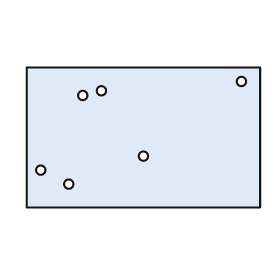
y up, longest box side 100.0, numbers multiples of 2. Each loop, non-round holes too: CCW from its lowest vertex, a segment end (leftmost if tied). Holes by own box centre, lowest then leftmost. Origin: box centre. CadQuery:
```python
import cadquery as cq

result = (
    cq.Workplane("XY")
    .moveTo(-50.0, -30.0)
    .lineTo(50.0, -30.0)
    .lineTo(50.0, 30.0)
    .lineTo(-50.0, 30.0)
    .close()
    .moveTo(-32.0, -20.0)
    .circle(2.0)
    .moveTo(-44.0, -14.0)
    .circle(2.0)
    .moveTo(0.0, -8.0)
    .circle(2.0)
    .moveTo(-26.0, 18.0)
    .circle(2.0)
    .moveTo(-18.0, 20.0)
    .circle(2.0)
    .moveTo(42.0, 24.0)
    .circle(2.0)
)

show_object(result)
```